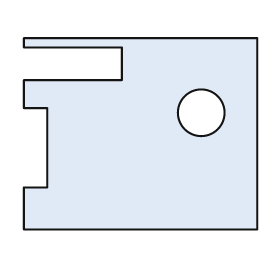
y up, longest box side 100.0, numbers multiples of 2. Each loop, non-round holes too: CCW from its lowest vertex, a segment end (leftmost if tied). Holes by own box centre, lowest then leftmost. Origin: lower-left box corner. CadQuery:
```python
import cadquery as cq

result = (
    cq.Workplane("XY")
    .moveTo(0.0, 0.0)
    .lineTo(100.0, 0.0)
    .lineTo(100.0, 82.0)
    .lineTo(0.0, 82.0)
    .lineTo(0.0, 78.0)
    .lineTo(42.0, 78.0)
    .lineTo(42.0, 64.0)
    .lineTo(0.0, 64.0)
    .lineTo(0.0, 52.0)
    .lineTo(10.0, 52.0)
    .lineTo(10.0, 18.0)
    .lineTo(0.0, 18.0)
    .close()
    .moveTo(76.0, 50.0)
    .circle(10.0)
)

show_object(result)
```